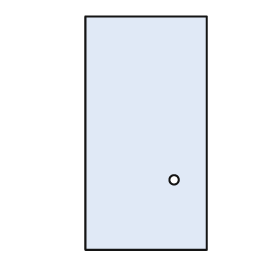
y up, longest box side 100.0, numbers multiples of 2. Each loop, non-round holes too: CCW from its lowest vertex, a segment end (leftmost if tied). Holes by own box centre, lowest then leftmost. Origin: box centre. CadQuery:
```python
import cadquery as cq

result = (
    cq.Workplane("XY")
    .moveTo(-26.0, -50.0)
    .lineTo(26.0, -50.0)
    .lineTo(26.0, 50.0)
    .lineTo(-26.0, 50.0)
    .close()
    .moveTo(12.0, -20.0)
    .circle(2.0)
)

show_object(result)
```